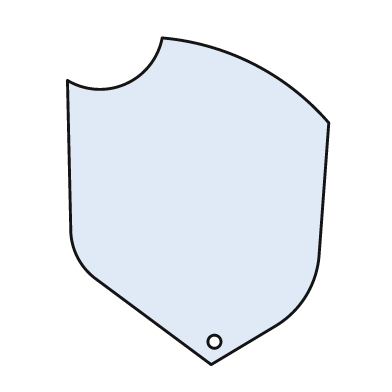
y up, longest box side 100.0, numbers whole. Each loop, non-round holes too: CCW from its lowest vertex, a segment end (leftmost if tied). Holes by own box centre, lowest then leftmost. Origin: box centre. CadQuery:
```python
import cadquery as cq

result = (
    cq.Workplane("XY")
    .moveTo(4.0, -50.0)
    .lineTo(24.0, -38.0)
    .threePointArc((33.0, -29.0), (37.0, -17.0))
    .lineTo(40.0, 24.0)
    .threePointArc((17.0, 42.0), (-11.0, 50.0))
    .threePointArc((-22.0, 36.0), (-40.0, 37.0))
    .lineTo(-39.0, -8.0)
    .threePointArc((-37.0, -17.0), (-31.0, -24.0))
    .close()
    .moveTo(5.0, -43.0)
    .circle(2.0)
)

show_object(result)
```